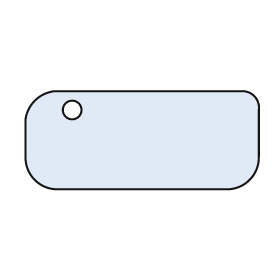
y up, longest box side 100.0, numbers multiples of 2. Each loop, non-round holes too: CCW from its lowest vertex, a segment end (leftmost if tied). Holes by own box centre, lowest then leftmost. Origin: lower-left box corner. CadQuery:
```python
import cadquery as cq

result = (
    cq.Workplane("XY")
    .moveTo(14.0, 0.0)
    .lineTo(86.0, 0.0)
    .threePointArc((96.0, 4.0), (100.0, 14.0))
    .lineTo(100.0, 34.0)
    .threePointArc((98.0, 40.0), (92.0, 42.0))
    .lineTo(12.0, 42.0)
    .threePointArc((4.0, 38.0), (0.0, 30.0))
    .lineTo(0.0, 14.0)
    .threePointArc((4.0, 4.0), (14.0, 0.0))
    .close()
    .moveTo(20.0, 34.0)
    .circle(4.0)
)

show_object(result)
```